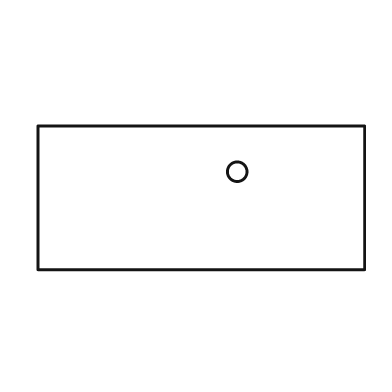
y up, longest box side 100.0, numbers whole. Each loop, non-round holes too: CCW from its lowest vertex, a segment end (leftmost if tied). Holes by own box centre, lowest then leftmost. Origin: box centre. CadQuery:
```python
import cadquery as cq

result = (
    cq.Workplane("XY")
    .moveTo(-50.0, -22.0)
    .lineTo(50.0, -22.0)
    .lineTo(50.0, 22.0)
    .lineTo(-50.0, 22.0)
    .close()
    .moveTo(11.0, 8.0)
    .circle(3.0)
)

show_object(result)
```